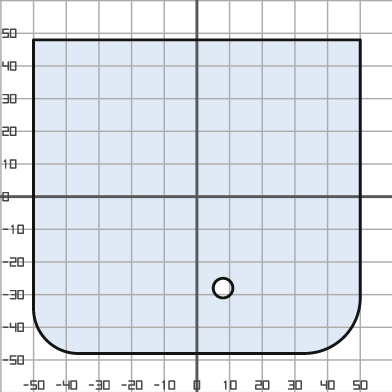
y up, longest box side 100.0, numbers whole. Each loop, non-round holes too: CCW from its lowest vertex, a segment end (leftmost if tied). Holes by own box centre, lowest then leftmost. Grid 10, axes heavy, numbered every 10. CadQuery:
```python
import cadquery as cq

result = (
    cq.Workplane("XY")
    .moveTo(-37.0, -48.0)
    .lineTo(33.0, -48.0)
    .threePointArc((45.0, -43.0), (50.0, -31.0))
    .lineTo(50.0, 48.0)
    .lineTo(-50.0, 48.0)
    .lineTo(-50.0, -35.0)
    .threePointArc((-46.0, -44.0), (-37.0, -48.0))
    .close()
    .moveTo(8.0, -28.0)
    .circle(3.0)
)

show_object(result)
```